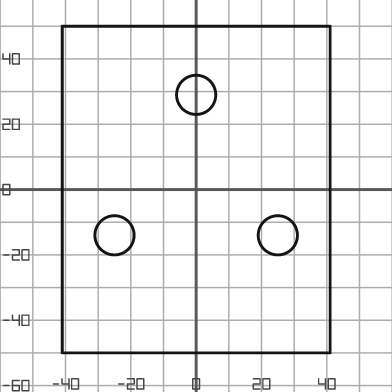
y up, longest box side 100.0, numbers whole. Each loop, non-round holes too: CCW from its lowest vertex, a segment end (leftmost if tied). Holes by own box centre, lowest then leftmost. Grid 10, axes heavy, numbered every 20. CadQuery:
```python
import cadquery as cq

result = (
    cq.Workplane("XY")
    .moveTo(-41.0, -50.0)
    .lineTo(41.0, -50.0)
    .lineTo(41.0, 50.0)
    .lineTo(-41.0, 50.0)
    .close()
    .moveTo(-25.0, -14.0)
    .circle(6.0)
    .moveTo(25.0, -14.0)
    .circle(6.0)
    .moveTo(0.0, 29.0)
    .circle(6.0)
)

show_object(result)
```